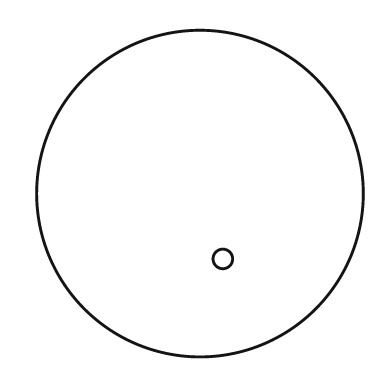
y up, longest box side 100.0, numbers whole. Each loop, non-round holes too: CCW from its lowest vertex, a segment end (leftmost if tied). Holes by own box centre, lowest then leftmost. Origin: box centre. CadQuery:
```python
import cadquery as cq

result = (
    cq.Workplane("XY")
    .moveTo(0.0, 0.0)
    .circle(50.0)
    .moveTo(7.0, -20.0)
    .circle(3.0)
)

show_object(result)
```